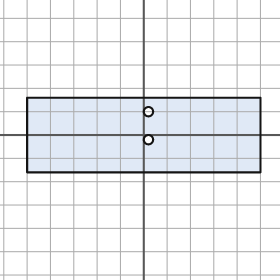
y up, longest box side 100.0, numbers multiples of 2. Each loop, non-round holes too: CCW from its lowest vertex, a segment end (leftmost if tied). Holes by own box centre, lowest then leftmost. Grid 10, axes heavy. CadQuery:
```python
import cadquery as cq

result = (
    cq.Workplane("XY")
    .moveTo(-50.0, -16.0)
    .lineTo(50.0, -16.0)
    .lineTo(50.0, 16.0)
    .lineTo(-50.0, 16.0)
    .close()
    .moveTo(2.0, -2.0)
    .circle(2.0)
    .moveTo(2.0, 10.0)
    .circle(2.0)
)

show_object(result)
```